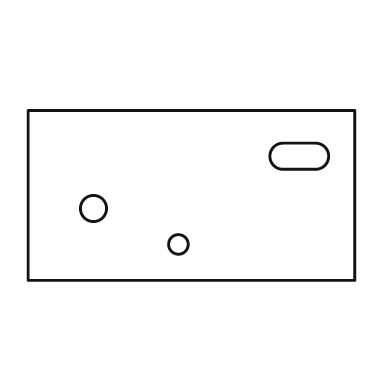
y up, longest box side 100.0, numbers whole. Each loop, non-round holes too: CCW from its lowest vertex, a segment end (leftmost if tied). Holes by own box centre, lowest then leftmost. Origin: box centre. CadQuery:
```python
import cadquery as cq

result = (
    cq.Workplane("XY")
    .moveTo(-50.0, -26.0)
    .lineTo(50.0, -26.0)
    .lineTo(50.0, 26.0)
    .lineTo(-50.0, 26.0)
    .close()
    .moveTo(-4.0, -15.0)
    .circle(3.0)
    .moveTo(-30.0, -4.0)
    .circle(4.0)
    .moveTo(28.0, 8.0)
    .lineTo(38.0, 8.0)
    .threePointArc((42.0, 12.0), (38.0, 16.0))
    .lineTo(28.0, 16.0)
    .threePointArc((24.0, 12.0), (28.0, 8.0))
    .close()
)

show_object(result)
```